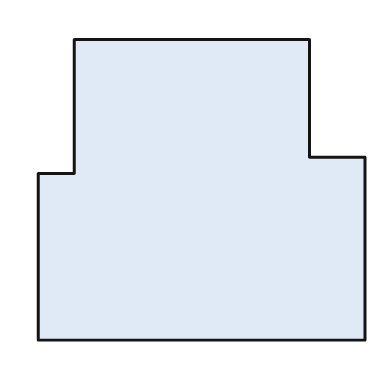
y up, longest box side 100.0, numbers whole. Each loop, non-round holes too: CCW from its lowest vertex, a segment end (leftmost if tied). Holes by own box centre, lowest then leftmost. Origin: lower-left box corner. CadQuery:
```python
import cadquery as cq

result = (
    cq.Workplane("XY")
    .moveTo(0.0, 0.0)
    .lineTo(100.0, 0.0)
    .lineTo(100.0, 56.0)
    .lineTo(83.0, 56.0)
    .lineTo(83.0, 92.0)
    .lineTo(11.0, 92.0)
    .lineTo(11.0, 51.0)
    .lineTo(0.0, 51.0)
    .close()
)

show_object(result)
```